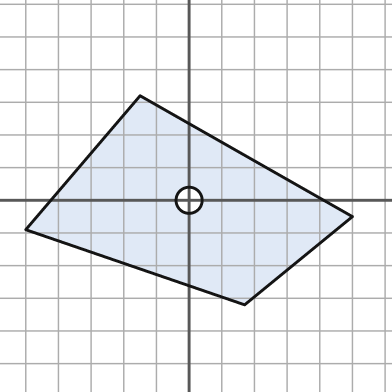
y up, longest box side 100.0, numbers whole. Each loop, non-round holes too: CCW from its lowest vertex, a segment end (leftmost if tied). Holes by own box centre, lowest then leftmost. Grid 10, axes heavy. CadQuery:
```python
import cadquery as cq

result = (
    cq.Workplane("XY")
    .moveTo(17.0, -32.0)
    .lineTo(50.0, -5.0)
    .lineTo(-15.0, 32.0)
    .lineTo(-50.0, -9.0)
    .close()
    .moveTo(0.0, 0.0)
    .circle(4.0)
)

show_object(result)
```